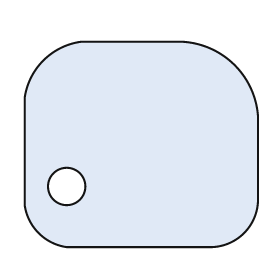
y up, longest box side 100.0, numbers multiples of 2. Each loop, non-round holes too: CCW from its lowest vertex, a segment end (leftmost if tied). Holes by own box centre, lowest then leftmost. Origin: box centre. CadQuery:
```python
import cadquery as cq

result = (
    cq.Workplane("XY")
    .moveTo(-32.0, -44.0)
    .lineTo(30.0, -44.0)
    .threePointArc((44.0, -38.0), (50.0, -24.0))
    .lineTo(50.0, 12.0)
    .threePointArc((40.0, 34.0), (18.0, 44.0))
    .lineTo(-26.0, 44.0)
    .threePointArc((-42.0, 36.0), (-50.0, 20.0))
    .lineTo(-50.0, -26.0)
    .threePointArc((-44.0, -38.0), (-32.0, -44.0))
    .close()
    .moveTo(-32.0, -18.0)
    .circle(8.0)
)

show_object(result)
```